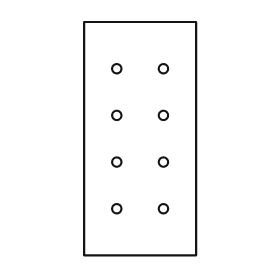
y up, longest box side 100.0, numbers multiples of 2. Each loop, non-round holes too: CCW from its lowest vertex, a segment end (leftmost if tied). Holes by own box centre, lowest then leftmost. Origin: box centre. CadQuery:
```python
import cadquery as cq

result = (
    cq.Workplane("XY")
    .moveTo(-24.0, -50.0)
    .lineTo(24.0, -50.0)
    .lineTo(24.0, 50.0)
    .lineTo(-24.0, 50.0)
    .close()
    .moveTo(-10.0, -30.0)
    .circle(2.0)
    .moveTo(10.0, -30.0)
    .circle(2.0)
    .moveTo(-10.0, -10.0)
    .circle(2.0)
    .moveTo(10.0, -10.0)
    .circle(2.0)
    .moveTo(-10.0, 10.0)
    .circle(2.0)
    .moveTo(10.0, 10.0)
    .circle(2.0)
    .moveTo(-10.0, 30.0)
    .circle(2.0)
    .moveTo(10.0, 30.0)
    .circle(2.0)
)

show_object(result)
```